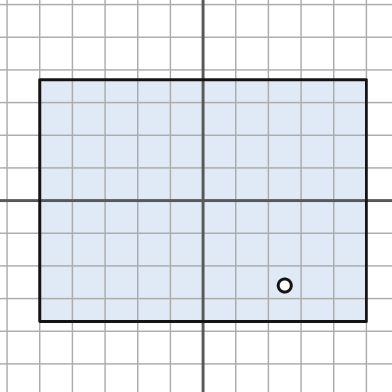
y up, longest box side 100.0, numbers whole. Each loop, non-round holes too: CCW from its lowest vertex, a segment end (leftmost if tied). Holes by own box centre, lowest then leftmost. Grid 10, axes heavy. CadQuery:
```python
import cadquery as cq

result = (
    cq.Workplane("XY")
    .moveTo(-50.0, -37.0)
    .lineTo(50.0, -37.0)
    .lineTo(50.0, 37.0)
    .lineTo(-50.0, 37.0)
    .close()
    .moveTo(25.0, -26.0)
    .circle(2.0)
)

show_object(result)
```